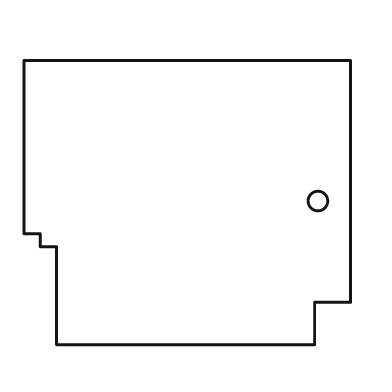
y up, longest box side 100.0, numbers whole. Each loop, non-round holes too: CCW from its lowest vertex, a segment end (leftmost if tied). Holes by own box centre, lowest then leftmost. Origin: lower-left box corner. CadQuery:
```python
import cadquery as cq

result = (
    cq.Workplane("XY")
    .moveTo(10.0, 0.0)
    .lineTo(89.0, 0.0)
    .lineTo(89.0, 13.0)
    .lineTo(100.0, 13.0)
    .lineTo(100.0, 87.0)
    .lineTo(0.0, 87.0)
    .lineTo(0.0, 34.0)
    .lineTo(5.0, 34.0)
    .lineTo(5.0, 30.0)
    .lineTo(10.0, 30.0)
    .close()
    .moveTo(90.0, 44.0)
    .circle(3.0)
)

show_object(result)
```